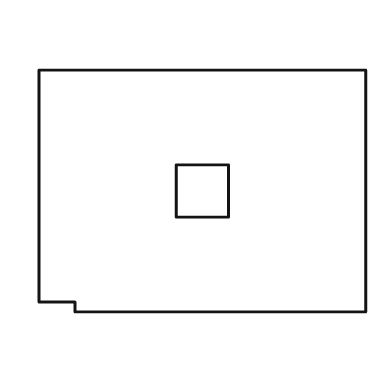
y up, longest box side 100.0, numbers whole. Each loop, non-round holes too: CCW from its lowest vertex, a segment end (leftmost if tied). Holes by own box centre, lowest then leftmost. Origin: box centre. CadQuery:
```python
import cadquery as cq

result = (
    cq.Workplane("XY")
    .moveTo(-39.0, -37.0)
    .lineTo(50.0, -37.0)
    .lineTo(50.0, 37.0)
    .lineTo(-50.0, 37.0)
    .lineTo(-50.0, -34.0)
    .lineTo(-39.0, -34.0)
    .close()
    .moveTo(-8.0, -8.0)
    .lineTo(8.0, -8.0)
    .lineTo(8.0, 8.0)
    .lineTo(-8.0, 8.0)
    .close()
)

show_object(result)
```